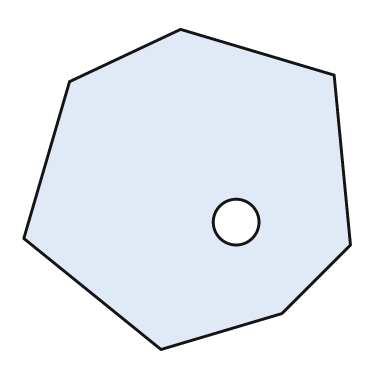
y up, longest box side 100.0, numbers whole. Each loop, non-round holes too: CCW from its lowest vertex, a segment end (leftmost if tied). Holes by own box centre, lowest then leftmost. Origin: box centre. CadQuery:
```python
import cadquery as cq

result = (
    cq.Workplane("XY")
    .moveTo(-8.0, -49.0)
    .lineTo(29.0, -38.0)
    .lineTo(50.0, -17.0)
    .lineTo(45.0, 35.0)
    .lineTo(-2.0, 49.0)
    .lineTo(-36.0, 33.0)
    .lineTo(-50.0, -15.0)
    .close()
    .moveTo(15.0, -10.0)
    .circle(7.0)
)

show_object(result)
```